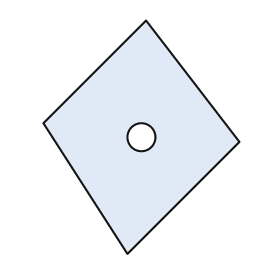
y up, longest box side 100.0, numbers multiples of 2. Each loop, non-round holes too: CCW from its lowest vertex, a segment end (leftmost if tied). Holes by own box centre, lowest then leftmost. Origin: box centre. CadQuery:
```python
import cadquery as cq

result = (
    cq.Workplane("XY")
    .moveTo(-6.0, -50.0)
    .lineTo(42.0, -2.0)
    .lineTo(2.0, 50.0)
    .lineTo(-42.0, 6.0)
    .close()
    .moveTo(0.0, 0.0)
    .circle(6.0)
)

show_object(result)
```